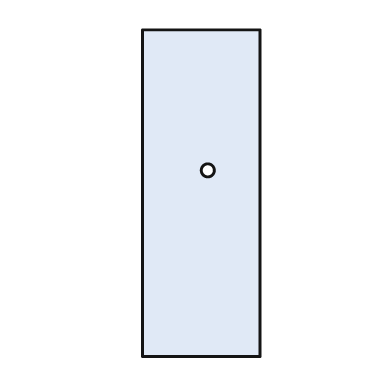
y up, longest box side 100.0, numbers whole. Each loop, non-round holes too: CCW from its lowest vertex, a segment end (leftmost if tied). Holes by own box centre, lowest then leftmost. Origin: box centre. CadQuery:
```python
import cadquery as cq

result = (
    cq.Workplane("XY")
    .moveTo(-18.0, -50.0)
    .lineTo(18.0, -50.0)
    .lineTo(18.0, 50.0)
    .lineTo(-18.0, 50.0)
    .close()
    .moveTo(2.0, 7.0)
    .circle(2.0)
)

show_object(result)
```